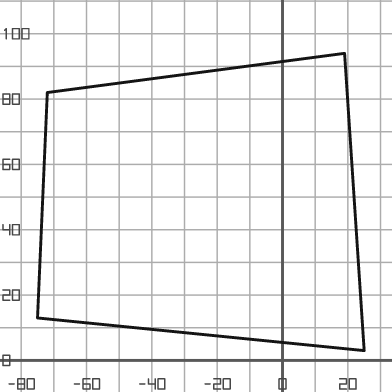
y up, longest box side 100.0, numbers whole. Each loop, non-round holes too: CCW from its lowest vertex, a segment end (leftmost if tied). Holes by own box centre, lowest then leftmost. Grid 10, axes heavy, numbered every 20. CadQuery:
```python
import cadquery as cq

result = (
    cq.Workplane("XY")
    .moveTo(25.0, 3.0)
    .lineTo(19.0, 94.0)
    .lineTo(-72.0, 82.0)
    .lineTo(-75.0, 13.0)
    .close()
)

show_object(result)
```